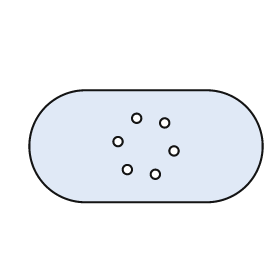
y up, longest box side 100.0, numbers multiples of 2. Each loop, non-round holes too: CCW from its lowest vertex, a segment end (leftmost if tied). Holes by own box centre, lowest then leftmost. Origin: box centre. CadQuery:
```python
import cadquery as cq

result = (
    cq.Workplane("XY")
    .moveTo(-26.0, -24.0)
    .lineTo(26.0, -24.0)
    .threePointArc((50.0, 0.0), (26.0, 24.0))
    .lineTo(-26.0, 24.0)
    .threePointArc((-50.0, 0.0), (-26.0, -24.0))
    .close()
    .moveTo(4.0, -12.0)
    .circle(2.0)
    .moveTo(-8.0, -10.0)
    .circle(2.0)
    .moveTo(12.0, -2.0)
    .circle(2.0)
    .moveTo(-12.0, 2.0)
    .circle(2.0)
    .moveTo(8.0, 10.0)
    .circle(2.0)
    .moveTo(-4.0, 12.0)
    .circle(2.0)
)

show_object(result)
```